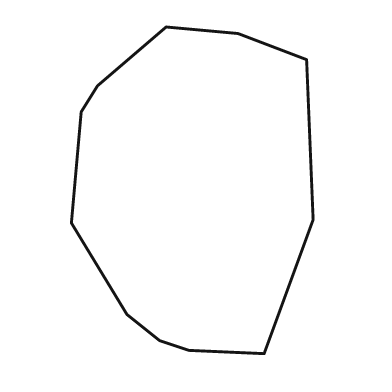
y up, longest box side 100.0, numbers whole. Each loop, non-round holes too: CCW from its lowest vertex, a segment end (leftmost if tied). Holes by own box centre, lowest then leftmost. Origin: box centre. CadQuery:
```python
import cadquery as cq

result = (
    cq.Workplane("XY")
    .moveTo(22.0, -50.0)
    .lineTo(37.0, -9.0)
    .lineTo(35.0, 40.0)
    .lineTo(14.0, 48.0)
    .lineTo(-8.0, 50.0)
    .lineTo(-29.0, 32.0)
    .lineTo(-34.0, 24.0)
    .lineTo(-37.0, -10.0)
    .lineTo(-20.0, -38.0)
    .lineTo(-10.0, -46.0)
    .lineTo(-1.0, -49.0)
    .close()
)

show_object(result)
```